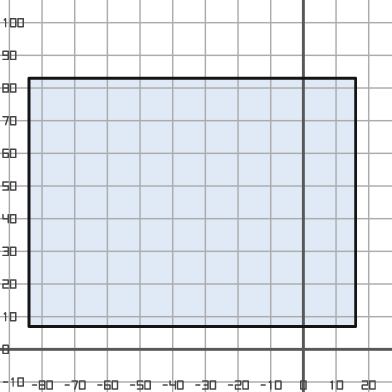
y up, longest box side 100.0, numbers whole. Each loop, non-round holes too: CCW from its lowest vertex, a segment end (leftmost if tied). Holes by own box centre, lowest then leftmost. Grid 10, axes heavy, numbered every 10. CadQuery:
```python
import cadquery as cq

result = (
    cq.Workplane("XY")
    .moveTo(-84.0, 7.0)
    .lineTo(16.0, 7.0)
    .lineTo(16.0, 83.0)
    .lineTo(-84.0, 83.0)
    .close()
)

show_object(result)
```